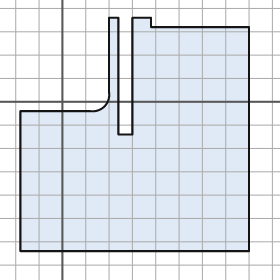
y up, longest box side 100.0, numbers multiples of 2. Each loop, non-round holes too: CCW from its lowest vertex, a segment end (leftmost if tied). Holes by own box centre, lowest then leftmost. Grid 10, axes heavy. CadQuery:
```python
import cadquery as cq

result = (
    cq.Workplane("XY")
    .moveTo(-18.0, -64.0)
    .lineTo(80.0, -64.0)
    .lineTo(80.0, 32.0)
    .lineTo(38.0, 32.0)
    .lineTo(38.0, 36.0)
    .lineTo(30.0, 36.0)
    .lineTo(30.0, -14.0)
    .lineTo(24.0, -14.0)
    .lineTo(24.0, 36.0)
    .lineTo(20.0, 36.0)
    .lineTo(20.0, 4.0)
    .threePointArc((18.0, -2.0), (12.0, -4.0))
    .lineTo(-18.0, -4.0)
    .close()
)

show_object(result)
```